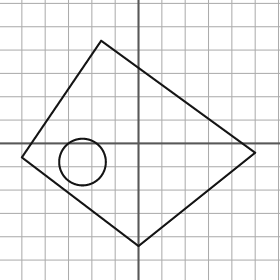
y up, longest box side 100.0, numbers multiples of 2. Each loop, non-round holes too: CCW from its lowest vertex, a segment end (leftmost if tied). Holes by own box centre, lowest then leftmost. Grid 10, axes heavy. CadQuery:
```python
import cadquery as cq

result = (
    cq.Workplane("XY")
    .moveTo(0.0, -44.0)
    .lineTo(50.0, -4.0)
    .lineTo(-16.0, 44.0)
    .lineTo(-50.0, -6.0)
    .close()
    .moveTo(-24.0, -8.0)
    .circle(10.0)
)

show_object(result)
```